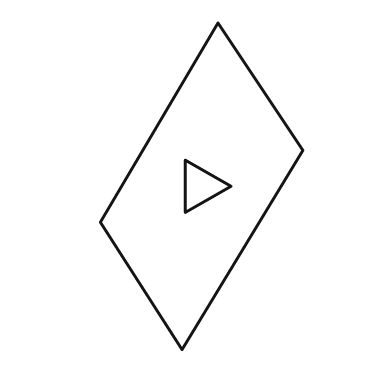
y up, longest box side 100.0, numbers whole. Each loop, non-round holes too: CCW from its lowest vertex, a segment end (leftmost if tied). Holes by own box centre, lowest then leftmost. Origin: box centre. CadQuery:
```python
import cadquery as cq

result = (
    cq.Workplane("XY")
    .moveTo(-6.0, -50.0)
    .lineTo(31.0, 11.0)
    .lineTo(5.0, 50.0)
    .lineTo(-31.0, -11.0)
    .close()
    .moveTo(-5.0, -8.0)
    .lineTo(9.0, 0.0)
    .lineTo(-5.0, 8.0)
    .close()
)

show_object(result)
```